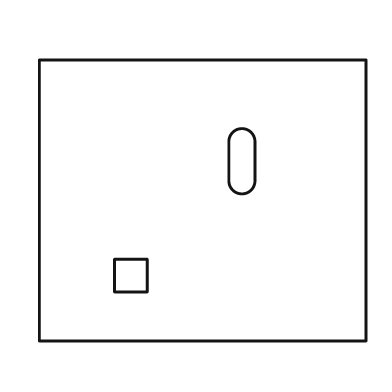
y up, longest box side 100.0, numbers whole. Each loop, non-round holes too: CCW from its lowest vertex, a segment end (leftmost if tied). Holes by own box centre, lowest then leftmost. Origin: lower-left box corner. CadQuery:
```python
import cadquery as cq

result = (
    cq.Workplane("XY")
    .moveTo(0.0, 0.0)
    .lineTo(100.0, 0.0)
    .lineTo(100.0, 86.0)
    .lineTo(0.0, 86.0)
    .close()
    .moveTo(23.0, 15.0)
    .lineTo(33.0, 15.0)
    .lineTo(33.0, 25.0)
    .lineTo(23.0, 25.0)
    .close()
    .moveTo(58.0, 49.0)
    .threePointArc((62.0, 45.0), (66.0, 49.0))
    .lineTo(66.0, 61.0)
    .threePointArc((62.0, 65.0), (58.0, 61.0))
    .close()
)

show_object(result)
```